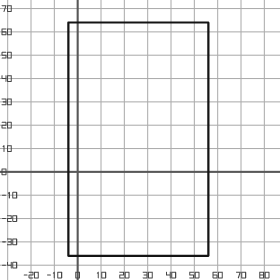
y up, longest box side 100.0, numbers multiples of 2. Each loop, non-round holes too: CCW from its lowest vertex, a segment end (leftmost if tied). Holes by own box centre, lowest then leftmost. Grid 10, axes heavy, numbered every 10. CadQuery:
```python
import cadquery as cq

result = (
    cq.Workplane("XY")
    .moveTo(-4.0, -36.0)
    .lineTo(56.0, -36.0)
    .lineTo(56.0, 64.0)
    .lineTo(-4.0, 64.0)
    .close()
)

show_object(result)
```